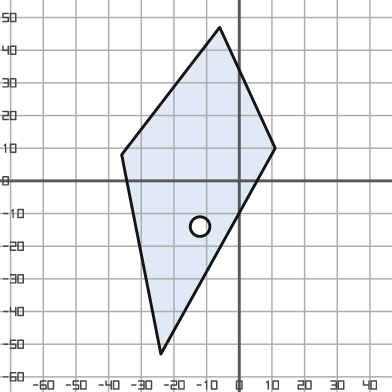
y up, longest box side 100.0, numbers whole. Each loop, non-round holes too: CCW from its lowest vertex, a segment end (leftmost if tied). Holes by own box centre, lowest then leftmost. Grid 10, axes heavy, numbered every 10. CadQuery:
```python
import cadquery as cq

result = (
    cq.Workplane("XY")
    .moveTo(-24.0, -53.0)
    .lineTo(11.0, 10.0)
    .lineTo(-6.0, 47.0)
    .lineTo(-36.0, 8.0)
    .close()
    .moveTo(-12.0, -14.0)
    .circle(3.0)
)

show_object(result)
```